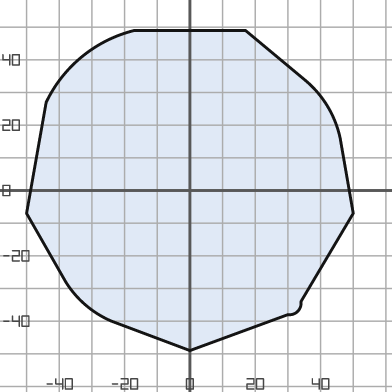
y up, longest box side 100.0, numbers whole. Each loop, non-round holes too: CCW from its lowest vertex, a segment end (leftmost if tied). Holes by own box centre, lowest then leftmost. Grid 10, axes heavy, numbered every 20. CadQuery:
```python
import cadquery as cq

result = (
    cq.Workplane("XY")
    .moveTo(0.0, -49.0)
    .lineTo(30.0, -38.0)
    .threePointArc((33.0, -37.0), (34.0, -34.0))
    .lineTo(50.0, -7.0)
    .lineTo(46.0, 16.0)
    .threePointArc((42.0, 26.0), (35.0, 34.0))
    .lineTo(17.0, 49.0)
    .lineTo(-17.0, 49.0)
    .threePointArc((-33.0, 41.0), (-44.0, 27.0))
    .lineTo(-50.0, -7.0)
    .lineTo(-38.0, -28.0)
    .threePointArc((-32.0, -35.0), (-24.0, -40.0))
    .close()
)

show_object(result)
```